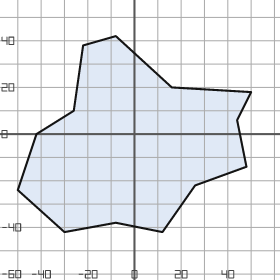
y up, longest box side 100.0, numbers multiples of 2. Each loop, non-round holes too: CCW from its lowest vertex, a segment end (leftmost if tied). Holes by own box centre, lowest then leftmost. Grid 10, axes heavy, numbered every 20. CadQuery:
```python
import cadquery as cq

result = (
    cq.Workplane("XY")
    .moveTo(-30.0, -42.0)
    .lineTo(-8.0, -38.0)
    .lineTo(12.0, -42.0)
    .lineTo(26.0, -22.0)
    .lineTo(48.0, -14.0)
    .lineTo(44.0, 6.0)
    .lineTo(50.0, 18.0)
    .lineTo(16.0, 20.0)
    .lineTo(-8.0, 42.0)
    .lineTo(-22.0, 38.0)
    .lineTo(-26.0, 10.0)
    .lineTo(-42.0, 0.0)
    .lineTo(-50.0, -24.0)
    .close()
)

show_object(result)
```